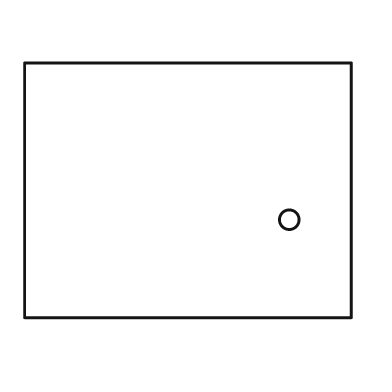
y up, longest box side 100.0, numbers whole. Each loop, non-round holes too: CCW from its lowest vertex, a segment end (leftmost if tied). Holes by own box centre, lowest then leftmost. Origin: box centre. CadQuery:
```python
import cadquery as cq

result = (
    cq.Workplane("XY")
    .moveTo(-50.0, -39.0)
    .lineTo(50.0, -39.0)
    .lineTo(50.0, 39.0)
    .lineTo(-50.0, 39.0)
    .close()
    .moveTo(31.0, -9.0)
    .circle(3.0)
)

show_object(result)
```